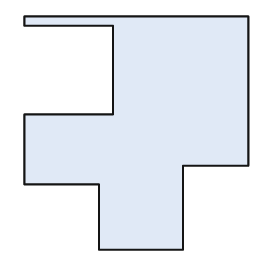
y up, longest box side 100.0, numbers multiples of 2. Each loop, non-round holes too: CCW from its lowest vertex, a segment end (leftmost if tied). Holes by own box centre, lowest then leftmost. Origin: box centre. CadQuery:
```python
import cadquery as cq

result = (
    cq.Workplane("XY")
    .moveTo(-16.0, -50.0)
    .lineTo(20.0, -50.0)
    .lineTo(20.0, -14.0)
    .lineTo(48.0, -14.0)
    .lineTo(48.0, 50.0)
    .lineTo(-48.0, 50.0)
    .lineTo(-48.0, 46.0)
    .lineTo(-10.0, 46.0)
    .lineTo(-10.0, 8.0)
    .lineTo(-48.0, 8.0)
    .lineTo(-48.0, -22.0)
    .lineTo(-16.0, -22.0)
    .close()
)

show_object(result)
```